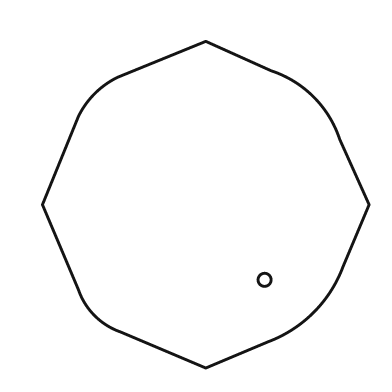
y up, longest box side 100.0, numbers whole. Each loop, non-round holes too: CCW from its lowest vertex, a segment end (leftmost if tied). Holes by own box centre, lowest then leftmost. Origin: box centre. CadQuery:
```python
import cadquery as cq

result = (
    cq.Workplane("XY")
    .moveTo(0.0, -50.0)
    .lineTo(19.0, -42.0)
    .threePointArc((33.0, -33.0), (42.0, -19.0))
    .lineTo(50.0, 0.0)
    .lineTo(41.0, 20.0)
    .threePointArc((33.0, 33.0), (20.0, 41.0))
    .lineTo(0.0, 50.0)
    .lineTo(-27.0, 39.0)
    .threePointArc((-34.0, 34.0), (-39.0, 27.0))
    .lineTo(-50.0, 0.0)
    .lineTo(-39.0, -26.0)
    .threePointArc((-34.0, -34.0), (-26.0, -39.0))
    .close()
    .moveTo(18.0, -23.0)
    .circle(2.0)
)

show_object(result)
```